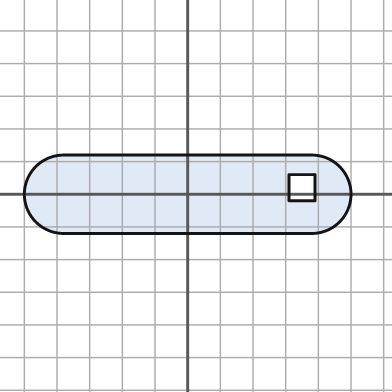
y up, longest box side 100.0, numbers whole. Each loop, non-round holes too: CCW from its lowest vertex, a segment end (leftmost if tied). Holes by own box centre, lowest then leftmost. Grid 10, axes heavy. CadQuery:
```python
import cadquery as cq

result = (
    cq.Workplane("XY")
    .moveTo(-38.0, -12.0)
    .lineTo(38.0, -12.0)
    .threePointArc((50.0, 0.0), (38.0, 12.0))
    .lineTo(-38.0, 12.0)
    .threePointArc((-50.0, 0.0), (-38.0, -12.0))
    .close()
    .moveTo(31.0, -2.0)
    .lineTo(39.0, -2.0)
    .lineTo(39.0, 6.0)
    .lineTo(31.0, 6.0)
    .close()
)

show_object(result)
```